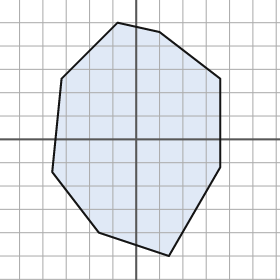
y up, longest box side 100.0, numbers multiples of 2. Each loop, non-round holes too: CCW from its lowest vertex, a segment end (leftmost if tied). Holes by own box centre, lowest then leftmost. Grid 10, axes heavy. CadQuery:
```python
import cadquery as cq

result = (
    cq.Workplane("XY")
    .moveTo(14.0, -50.0)
    .lineTo(36.0, -12.0)
    .lineTo(36.0, 26.0)
    .lineTo(10.0, 46.0)
    .lineTo(-8.0, 50.0)
    .lineTo(-32.0, 26.0)
    .lineTo(-36.0, -14.0)
    .lineTo(-16.0, -40.0)
    .close()
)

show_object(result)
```